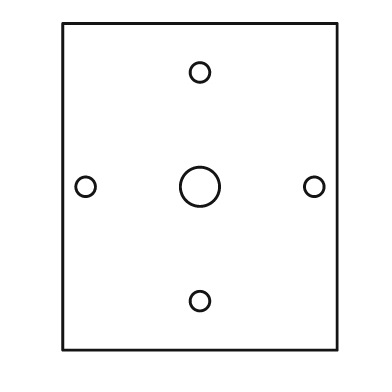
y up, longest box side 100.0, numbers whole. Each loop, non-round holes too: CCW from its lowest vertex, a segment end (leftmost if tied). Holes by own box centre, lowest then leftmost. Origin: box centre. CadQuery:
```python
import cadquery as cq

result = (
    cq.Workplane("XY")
    .moveTo(-42.0, -50.0)
    .lineTo(42.0, -50.0)
    .lineTo(42.0, 50.0)
    .lineTo(-42.0, 50.0)
    .close()
    .moveTo(0.0, -35.0)
    .circle(3.0)
    .moveTo(-35.0, 0.0)
    .circle(3.0)
    .moveTo(0.0, 0.0)
    .circle(6.0)
    .moveTo(35.0, 0.0)
    .circle(3.0)
    .moveTo(0.0, 35.0)
    .circle(3.0)
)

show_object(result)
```